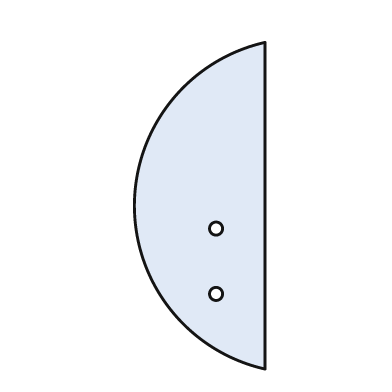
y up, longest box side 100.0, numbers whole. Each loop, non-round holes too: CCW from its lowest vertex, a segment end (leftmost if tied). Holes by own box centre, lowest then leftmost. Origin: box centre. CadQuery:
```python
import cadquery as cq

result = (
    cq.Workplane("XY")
    .moveTo(20.0, -50.0)
    .lineTo(20.0, 50.0)
    .threePointArc((-20.0, 0.0), (20.0, -50.0))
    .close()
    .moveTo(5.0, -27.0)
    .circle(2.0)
    .moveTo(5.0, -7.0)
    .circle(2.0)
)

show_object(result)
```